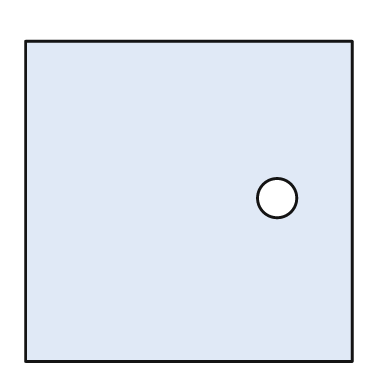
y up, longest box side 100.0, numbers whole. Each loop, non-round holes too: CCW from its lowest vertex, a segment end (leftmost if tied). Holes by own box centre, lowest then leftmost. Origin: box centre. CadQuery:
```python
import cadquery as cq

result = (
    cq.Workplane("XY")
    .moveTo(-50.0, -49.0)
    .lineTo(50.0, -49.0)
    .lineTo(50.0, 49.0)
    .lineTo(-50.0, 49.0)
    .close()
    .moveTo(27.0, 1.0)
    .circle(6.0)
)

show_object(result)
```